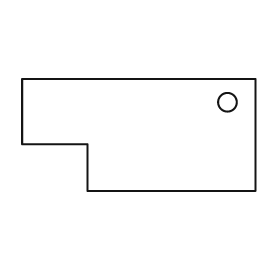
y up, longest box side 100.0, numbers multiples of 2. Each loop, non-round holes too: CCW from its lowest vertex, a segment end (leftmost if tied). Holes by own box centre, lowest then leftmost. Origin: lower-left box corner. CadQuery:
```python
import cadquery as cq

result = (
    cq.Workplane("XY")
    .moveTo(28.0, 0.0)
    .lineTo(100.0, 0.0)
    .lineTo(100.0, 48.0)
    .lineTo(0.0, 48.0)
    .lineTo(0.0, 20.0)
    .lineTo(28.0, 20.0)
    .close()
    .moveTo(88.0, 38.0)
    .circle(4.0)
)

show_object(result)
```